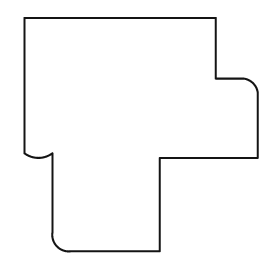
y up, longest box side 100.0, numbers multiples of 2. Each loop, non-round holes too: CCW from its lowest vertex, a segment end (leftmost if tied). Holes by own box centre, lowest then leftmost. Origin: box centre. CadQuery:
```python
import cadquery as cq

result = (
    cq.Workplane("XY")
    .moveTo(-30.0, -50.0)
    .lineTo(8.0, -50.0)
    .lineTo(8.0, -10.0)
    .lineTo(50.0, -10.0)
    .lineTo(50.0, 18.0)
    .threePointArc((48.0, 22.0), (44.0, 24.0))
    .lineTo(32.0, 24.0)
    .lineTo(32.0, 50.0)
    .lineTo(-50.0, 50.0)
    .lineTo(-50.0, -8.0)
    .threePointArc((-44.0, -10.0), (-38.0, -8.0))
    .lineTo(-38.0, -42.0)
    .threePointArc((-36.0, -48.0), (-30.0, -50.0))
    .close()
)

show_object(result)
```